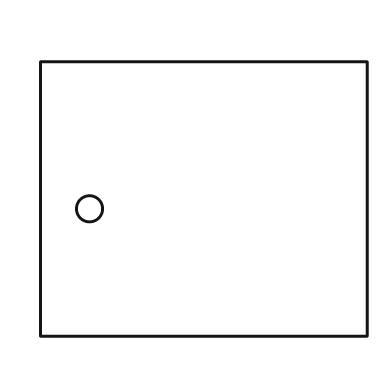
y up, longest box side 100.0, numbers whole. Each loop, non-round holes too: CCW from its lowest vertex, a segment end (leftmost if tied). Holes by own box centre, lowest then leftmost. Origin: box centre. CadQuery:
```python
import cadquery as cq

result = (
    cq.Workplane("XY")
    .moveTo(-50.0, -42.0)
    .lineTo(50.0, -42.0)
    .lineTo(50.0, 42.0)
    .lineTo(-50.0, 42.0)
    .close()
    .moveTo(-35.0, -3.0)
    .circle(4.0)
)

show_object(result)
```